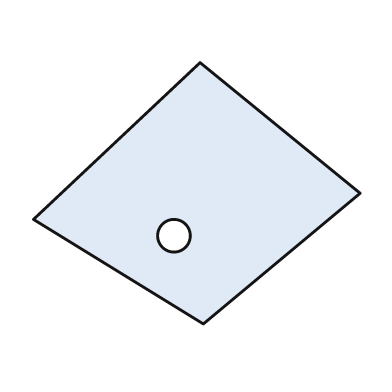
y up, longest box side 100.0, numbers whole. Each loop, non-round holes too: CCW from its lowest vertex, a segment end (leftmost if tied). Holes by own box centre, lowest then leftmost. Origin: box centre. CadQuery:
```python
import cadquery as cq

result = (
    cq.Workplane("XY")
    .moveTo(2.0, -40.0)
    .lineTo(50.0, 0.0)
    .lineTo(1.0, 40.0)
    .lineTo(-50.0, -8.0)
    .close()
    .moveTo(-7.0, -13.0)
    .circle(5.0)
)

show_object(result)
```